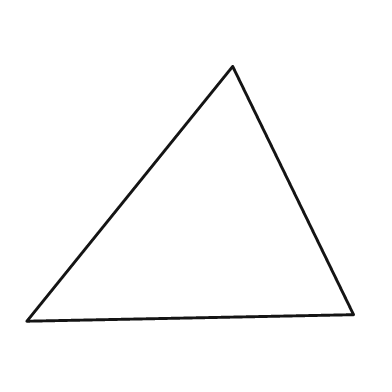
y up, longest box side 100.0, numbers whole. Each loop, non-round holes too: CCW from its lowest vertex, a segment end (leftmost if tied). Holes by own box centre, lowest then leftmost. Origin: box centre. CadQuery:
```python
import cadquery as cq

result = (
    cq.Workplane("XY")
    .moveTo(-50.0, -39.0)
    .lineTo(50.0, -37.0)
    .lineTo(13.0, 39.0)
    .close()
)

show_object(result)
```